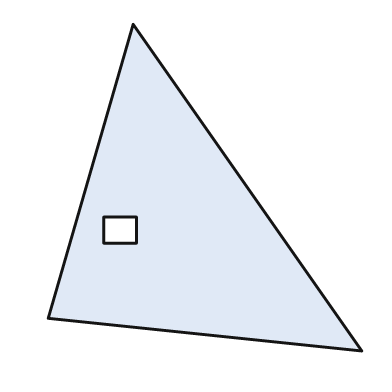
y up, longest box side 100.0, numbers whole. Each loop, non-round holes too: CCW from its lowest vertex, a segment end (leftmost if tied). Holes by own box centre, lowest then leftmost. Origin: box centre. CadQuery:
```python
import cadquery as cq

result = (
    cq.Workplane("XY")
    .moveTo(48.0, -50.0)
    .lineTo(-22.0, 50.0)
    .lineTo(-48.0, -40.0)
    .close()
    .moveTo(-31.0, -17.0)
    .lineTo(-21.0, -17.0)
    .lineTo(-21.0, -9.0)
    .lineTo(-31.0, -9.0)
    .close()
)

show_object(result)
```